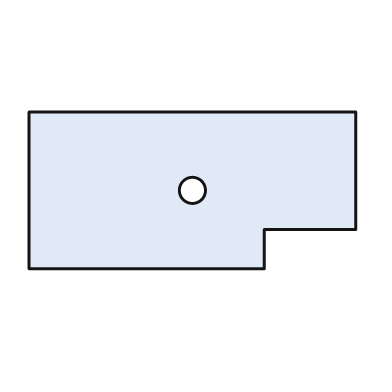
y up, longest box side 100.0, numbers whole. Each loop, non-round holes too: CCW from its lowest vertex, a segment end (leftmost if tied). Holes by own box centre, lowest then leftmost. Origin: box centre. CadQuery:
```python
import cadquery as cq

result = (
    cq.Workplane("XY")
    .moveTo(-50.0, -24.0)
    .lineTo(22.0, -24.0)
    .lineTo(22.0, -12.0)
    .lineTo(50.0, -12.0)
    .lineTo(50.0, 24.0)
    .lineTo(-50.0, 24.0)
    .close()
    .moveTo(0.0, 0.0)
    .circle(4.0)
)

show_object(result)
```